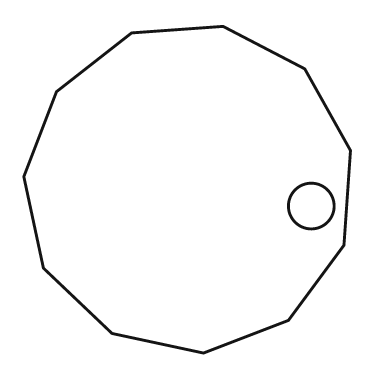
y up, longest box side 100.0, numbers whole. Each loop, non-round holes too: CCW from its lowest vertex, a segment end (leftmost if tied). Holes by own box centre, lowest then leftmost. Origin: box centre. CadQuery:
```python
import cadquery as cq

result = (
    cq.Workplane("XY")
    .moveTo(5.0, -50.0)
    .lineTo(31.0, -40.0)
    .lineTo(48.0, -17.0)
    .lineTo(50.0, 12.0)
    .lineTo(36.0, 37.0)
    .lineTo(11.0, 50.0)
    .lineTo(-17.0, 48.0)
    .lineTo(-40.0, 30.0)
    .lineTo(-50.0, 4.0)
    .lineTo(-44.0, -24.0)
    .lineTo(-23.0, -44.0)
    .close()
    .moveTo(38.0, -5.0)
    .circle(7.0)
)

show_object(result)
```